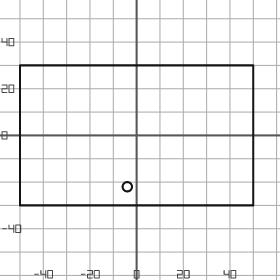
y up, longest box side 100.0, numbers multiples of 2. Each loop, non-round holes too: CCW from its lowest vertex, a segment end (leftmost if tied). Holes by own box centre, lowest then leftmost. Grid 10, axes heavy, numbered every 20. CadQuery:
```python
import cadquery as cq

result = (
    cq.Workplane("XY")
    .moveTo(-50.0, -30.0)
    .lineTo(50.0, -30.0)
    .lineTo(50.0, 30.0)
    .lineTo(-50.0, 30.0)
    .close()
    .moveTo(-4.0, -22.0)
    .circle(2.0)
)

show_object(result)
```